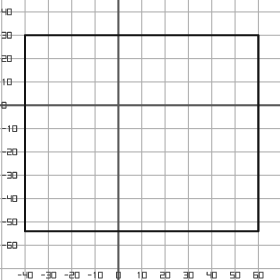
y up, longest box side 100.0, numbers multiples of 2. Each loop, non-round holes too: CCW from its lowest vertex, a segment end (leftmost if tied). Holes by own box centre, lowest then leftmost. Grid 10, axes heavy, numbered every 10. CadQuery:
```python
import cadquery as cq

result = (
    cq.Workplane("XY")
    .moveTo(-40.0, -54.0)
    .lineTo(60.0, -54.0)
    .lineTo(60.0, 30.0)
    .lineTo(-40.0, 30.0)
    .close()
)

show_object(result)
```